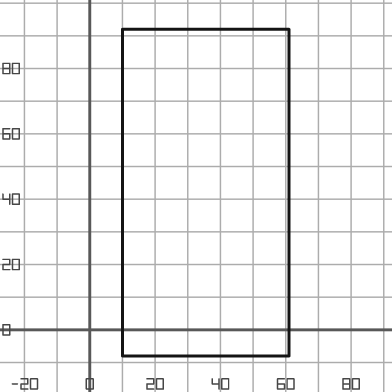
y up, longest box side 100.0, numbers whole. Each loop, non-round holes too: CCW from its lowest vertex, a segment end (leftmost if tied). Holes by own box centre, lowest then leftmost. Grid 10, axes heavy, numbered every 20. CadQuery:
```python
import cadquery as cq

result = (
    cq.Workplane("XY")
    .moveTo(10.0, -8.0)
    .lineTo(61.0, -8.0)
    .lineTo(61.0, 92.0)
    .lineTo(10.0, 92.0)
    .close()
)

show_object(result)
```